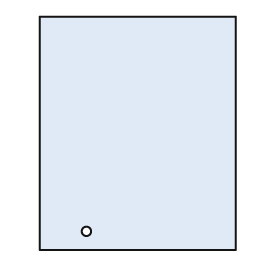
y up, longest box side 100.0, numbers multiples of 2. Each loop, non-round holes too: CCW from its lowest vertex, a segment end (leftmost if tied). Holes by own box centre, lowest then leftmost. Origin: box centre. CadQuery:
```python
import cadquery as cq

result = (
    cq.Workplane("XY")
    .moveTo(-42.0, -50.0)
    .lineTo(42.0, -50.0)
    .lineTo(42.0, 50.0)
    .lineTo(-42.0, 50.0)
    .close()
    .moveTo(-22.0, -42.0)
    .circle(2.0)
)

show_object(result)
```